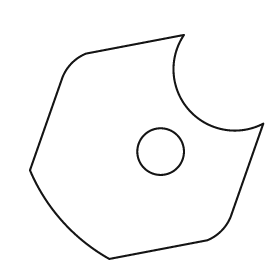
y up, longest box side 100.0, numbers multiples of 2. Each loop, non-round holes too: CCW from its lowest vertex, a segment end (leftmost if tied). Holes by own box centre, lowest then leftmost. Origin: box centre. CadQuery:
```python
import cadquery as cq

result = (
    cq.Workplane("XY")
    .moveTo(-16.0, -48.0)
    .lineTo(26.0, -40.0)
    .threePointArc((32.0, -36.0), (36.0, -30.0))
    .lineTo(50.0, 10.0)
    .threePointArc((18.0, 16.0), (16.0, 48.0))
    .lineTo(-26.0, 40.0)
    .threePointArc((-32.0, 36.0), (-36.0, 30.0))
    .lineTo(-50.0, -10.0)
    .threePointArc((-36.0, -32.0), (-16.0, -48.0))
    .close()
    .moveTo(6.0, -2.0)
    .circle(10.0)
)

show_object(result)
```